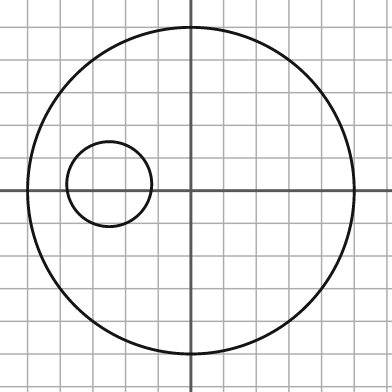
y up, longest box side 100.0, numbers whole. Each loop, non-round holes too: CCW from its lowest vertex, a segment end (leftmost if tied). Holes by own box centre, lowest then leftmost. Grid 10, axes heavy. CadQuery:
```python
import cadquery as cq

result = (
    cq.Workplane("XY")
    .moveTo(0.0, 0.0)
    .circle(50.0)
    .moveTo(-25.0, 2.0)
    .circle(13.0)
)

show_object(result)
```